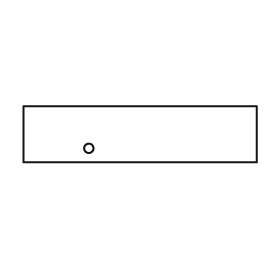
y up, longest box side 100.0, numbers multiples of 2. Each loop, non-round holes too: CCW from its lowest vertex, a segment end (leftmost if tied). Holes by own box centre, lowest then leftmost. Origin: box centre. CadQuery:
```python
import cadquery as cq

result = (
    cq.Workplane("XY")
    .moveTo(-50.0, -12.0)
    .lineTo(50.0, -12.0)
    .lineTo(50.0, 12.0)
    .lineTo(-50.0, 12.0)
    .close()
    .moveTo(-22.0, -6.0)
    .circle(2.0)
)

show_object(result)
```